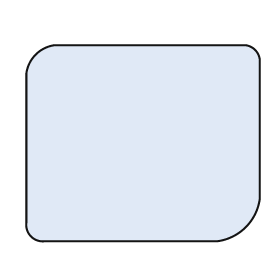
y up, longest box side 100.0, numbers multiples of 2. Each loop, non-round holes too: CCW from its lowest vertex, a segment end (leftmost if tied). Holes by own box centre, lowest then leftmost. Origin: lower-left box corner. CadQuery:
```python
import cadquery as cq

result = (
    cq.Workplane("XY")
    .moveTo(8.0, 0.0)
    .lineTo(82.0, 0.0)
    .threePointArc((94.0, 6.0), (100.0, 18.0))
    .lineTo(100.0, 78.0)
    .threePointArc((98.0, 82.0), (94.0, 84.0))
    .lineTo(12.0, 84.0)
    .threePointArc((4.0, 80.0), (0.0, 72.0))
    .lineTo(0.0, 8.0)
    .threePointArc((2.0, 2.0), (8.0, 0.0))
    .close()
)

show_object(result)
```